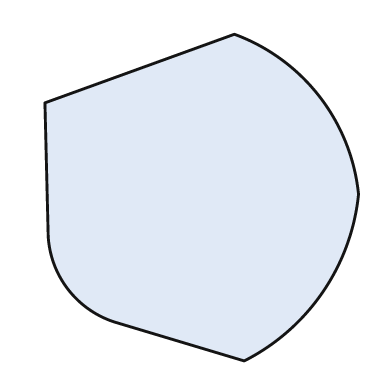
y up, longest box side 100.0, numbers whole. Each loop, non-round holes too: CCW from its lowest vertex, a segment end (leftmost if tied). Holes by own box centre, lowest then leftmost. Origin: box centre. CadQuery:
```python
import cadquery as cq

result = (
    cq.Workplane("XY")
    .moveTo(13.0, -50.0)
    .threePointArc((37.0, -29.0), (48.0, 1.0))
    .threePointArc((36.0, 31.0), (10.0, 50.0))
    .lineTo(-48.0, 29.0)
    .lineTo(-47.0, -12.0)
    .threePointArc((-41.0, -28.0), (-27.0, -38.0))
    .close()
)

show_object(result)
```